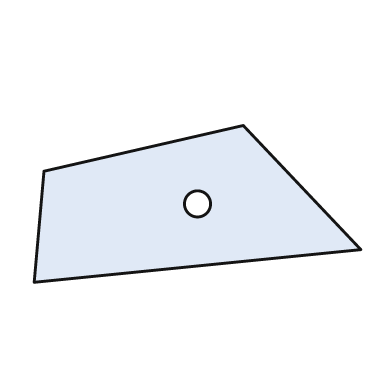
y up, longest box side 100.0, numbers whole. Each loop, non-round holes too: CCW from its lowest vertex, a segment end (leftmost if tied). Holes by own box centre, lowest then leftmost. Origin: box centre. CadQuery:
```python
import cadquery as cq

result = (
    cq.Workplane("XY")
    .moveTo(-50.0, -24.0)
    .lineTo(50.0, -14.0)
    .lineTo(14.0, 24.0)
    .lineTo(-47.0, 10.0)
    .close()
    .moveTo(0.0, 0.0)
    .circle(4.0)
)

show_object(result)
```